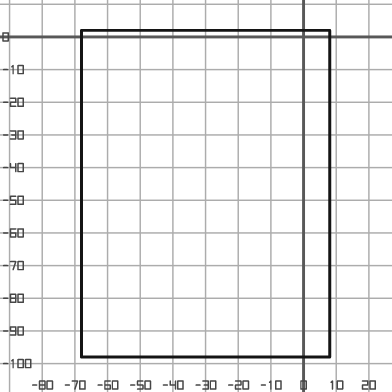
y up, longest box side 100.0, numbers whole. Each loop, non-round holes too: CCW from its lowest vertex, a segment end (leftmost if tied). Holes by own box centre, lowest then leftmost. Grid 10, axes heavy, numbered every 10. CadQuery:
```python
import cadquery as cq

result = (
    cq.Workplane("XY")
    .moveTo(-68.0, -98.0)
    .lineTo(8.0, -98.0)
    .lineTo(8.0, 2.0)
    .lineTo(-68.0, 2.0)
    .close()
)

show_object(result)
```